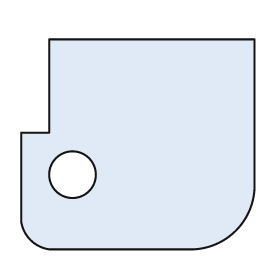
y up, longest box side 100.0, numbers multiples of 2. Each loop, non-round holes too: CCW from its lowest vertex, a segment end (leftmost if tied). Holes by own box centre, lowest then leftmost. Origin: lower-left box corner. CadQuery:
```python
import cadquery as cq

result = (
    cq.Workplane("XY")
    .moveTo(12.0, 0.0)
    .lineTo(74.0, 0.0)
    .threePointArc((92.0, 8.0), (100.0, 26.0))
    .lineTo(100.0, 90.0)
    .lineTo(12.0, 90.0)
    .lineTo(12.0, 50.0)
    .lineTo(0.0, 50.0)
    .lineTo(0.0, 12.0)
    .threePointArc((4.0, 4.0), (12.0, 0.0))
    .close()
    .moveTo(22.0, 32.0)
    .circle(10.0)
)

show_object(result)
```